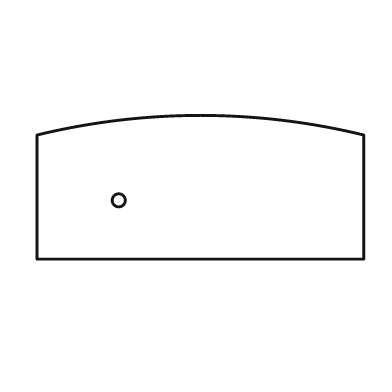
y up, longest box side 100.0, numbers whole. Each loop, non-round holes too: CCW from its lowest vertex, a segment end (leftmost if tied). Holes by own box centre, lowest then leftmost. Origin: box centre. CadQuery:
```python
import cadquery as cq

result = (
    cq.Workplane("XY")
    .moveTo(-50.0, -22.0)
    .lineTo(50.0, -22.0)
    .lineTo(50.0, 16.0)
    .threePointArc((0.0, 22.0), (-50.0, 16.0))
    .close()
    .moveTo(-25.0, -4.0)
    .circle(2.0)
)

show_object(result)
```